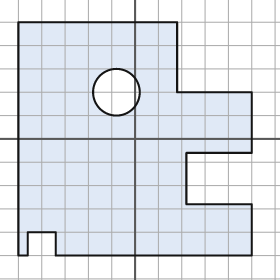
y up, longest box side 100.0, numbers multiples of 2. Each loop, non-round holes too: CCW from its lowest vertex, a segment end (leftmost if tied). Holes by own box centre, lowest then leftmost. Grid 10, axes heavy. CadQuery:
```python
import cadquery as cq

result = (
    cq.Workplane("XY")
    .moveTo(-50.0, -50.0)
    .lineTo(-46.0, -50.0)
    .lineTo(-46.0, -40.0)
    .lineTo(-34.0, -40.0)
    .lineTo(-34.0, -50.0)
    .lineTo(50.0, -50.0)
    .lineTo(50.0, -28.0)
    .lineTo(22.0, -28.0)
    .lineTo(22.0, -6.0)
    .lineTo(50.0, -6.0)
    .lineTo(50.0, 20.0)
    .lineTo(18.0, 20.0)
    .lineTo(18.0, 50.0)
    .lineTo(-50.0, 50.0)
    .close()
    .moveTo(-8.0, 20.0)
    .circle(10.0)
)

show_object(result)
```